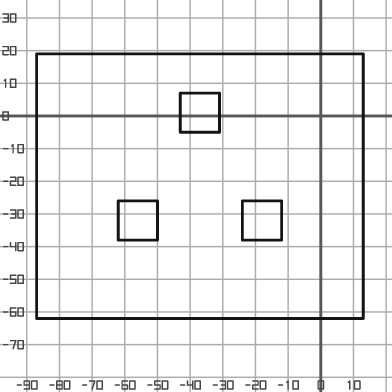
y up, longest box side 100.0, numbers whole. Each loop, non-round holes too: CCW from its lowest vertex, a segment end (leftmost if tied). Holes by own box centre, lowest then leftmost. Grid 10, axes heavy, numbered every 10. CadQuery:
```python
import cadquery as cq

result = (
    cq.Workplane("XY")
    .moveTo(-87.0, -62.0)
    .lineTo(13.0, -62.0)
    .lineTo(13.0, 19.0)
    .lineTo(-87.0, 19.0)
    .close()
    .moveTo(-62.0, -38.0)
    .lineTo(-50.0, -38.0)
    .lineTo(-50.0, -26.0)
    .lineTo(-62.0, -26.0)
    .close()
    .moveTo(-24.0, -38.0)
    .lineTo(-12.0, -38.0)
    .lineTo(-12.0, -26.0)
    .lineTo(-24.0, -26.0)
    .close()
    .moveTo(-43.0, -5.0)
    .lineTo(-31.0, -5.0)
    .lineTo(-31.0, 7.0)
    .lineTo(-43.0, 7.0)
    .close()
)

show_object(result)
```